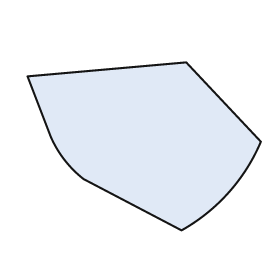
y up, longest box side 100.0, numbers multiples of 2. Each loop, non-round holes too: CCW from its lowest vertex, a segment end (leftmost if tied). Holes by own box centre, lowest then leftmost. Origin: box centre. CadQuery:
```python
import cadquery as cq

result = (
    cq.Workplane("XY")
    .moveTo(16.0, -36.0)
    .threePointArc((36.0, -20.0), (50.0, 2.0))
    .lineTo(18.0, 36.0)
    .lineTo(-50.0, 30.0)
    .lineTo(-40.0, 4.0)
    .threePointArc((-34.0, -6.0), (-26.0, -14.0))
    .close()
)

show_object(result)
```